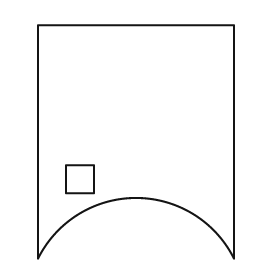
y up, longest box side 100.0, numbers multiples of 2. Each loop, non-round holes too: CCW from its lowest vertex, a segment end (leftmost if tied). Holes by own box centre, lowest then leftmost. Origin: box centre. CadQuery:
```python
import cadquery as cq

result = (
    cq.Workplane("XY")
    .moveTo(-42.0, -50.0)
    .threePointArc((0.0, -24.0), (42.0, -50.0))
    .lineTo(42.0, 50.0)
    .lineTo(-42.0, 50.0)
    .close()
    .moveTo(-30.0, -22.0)
    .lineTo(-18.0, -22.0)
    .lineTo(-18.0, -10.0)
    .lineTo(-30.0, -10.0)
    .close()
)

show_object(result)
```